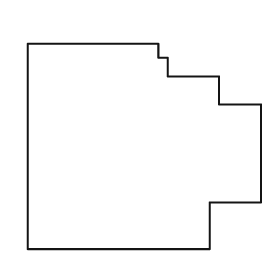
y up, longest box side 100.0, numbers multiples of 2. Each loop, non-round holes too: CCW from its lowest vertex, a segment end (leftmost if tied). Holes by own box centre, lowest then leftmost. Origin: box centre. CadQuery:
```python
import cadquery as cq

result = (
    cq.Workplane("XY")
    .moveTo(-50.0, -44.0)
    .lineTo(28.0, -44.0)
    .lineTo(28.0, -24.0)
    .lineTo(50.0, -24.0)
    .lineTo(50.0, 18.0)
    .lineTo(32.0, 18.0)
    .lineTo(32.0, 30.0)
    .lineTo(10.0, 30.0)
    .lineTo(10.0, 38.0)
    .lineTo(6.0, 38.0)
    .lineTo(6.0, 44.0)
    .lineTo(-50.0, 44.0)
    .close()
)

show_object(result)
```